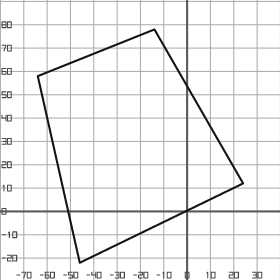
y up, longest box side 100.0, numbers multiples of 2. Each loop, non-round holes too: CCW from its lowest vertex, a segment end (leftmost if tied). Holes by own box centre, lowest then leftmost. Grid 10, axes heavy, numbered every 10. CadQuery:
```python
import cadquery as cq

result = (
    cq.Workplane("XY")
    .moveTo(-46.0, -22.0)
    .lineTo(24.0, 12.0)
    .lineTo(-14.0, 78.0)
    .lineTo(-64.0, 58.0)
    .close()
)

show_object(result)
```